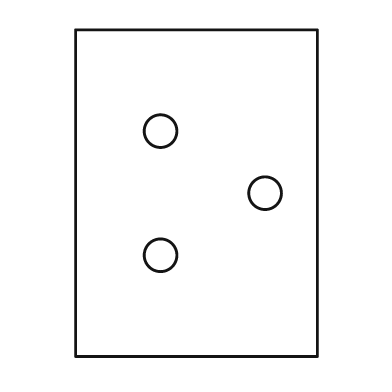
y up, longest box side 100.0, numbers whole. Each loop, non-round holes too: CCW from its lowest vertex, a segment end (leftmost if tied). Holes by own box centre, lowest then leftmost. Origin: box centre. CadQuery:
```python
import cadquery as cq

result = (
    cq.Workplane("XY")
    .moveTo(-37.0, -50.0)
    .lineTo(37.0, -50.0)
    .lineTo(37.0, 50.0)
    .lineTo(-37.0, 50.0)
    .close()
    .moveTo(-11.0, -19.0)
    .circle(5.0)
    .moveTo(21.0, 0.0)
    .circle(5.0)
    .moveTo(-11.0, 19.0)
    .circle(5.0)
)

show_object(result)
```